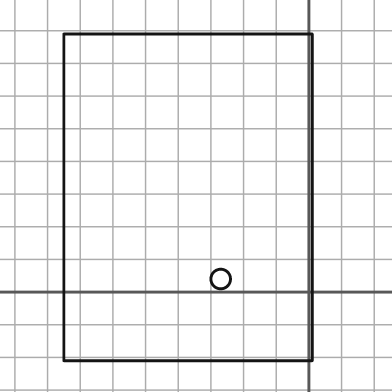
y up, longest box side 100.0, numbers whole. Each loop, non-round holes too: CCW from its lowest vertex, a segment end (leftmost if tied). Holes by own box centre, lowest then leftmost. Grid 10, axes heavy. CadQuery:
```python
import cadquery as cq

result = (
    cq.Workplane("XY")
    .moveTo(-75.0, -21.0)
    .lineTo(1.0, -21.0)
    .lineTo(1.0, 79.0)
    .lineTo(-75.0, 79.0)
    .close()
    .moveTo(-27.0, 4.0)
    .circle(3.0)
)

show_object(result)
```